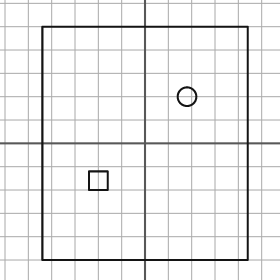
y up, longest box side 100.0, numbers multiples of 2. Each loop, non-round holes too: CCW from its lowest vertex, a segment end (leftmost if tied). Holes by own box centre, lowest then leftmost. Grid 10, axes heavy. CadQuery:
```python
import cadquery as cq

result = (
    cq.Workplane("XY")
    .moveTo(-44.0, -50.0)
    .lineTo(44.0, -50.0)
    .lineTo(44.0, 50.0)
    .lineTo(-44.0, 50.0)
    .close()
    .moveTo(-24.0, -20.0)
    .lineTo(-16.0, -20.0)
    .lineTo(-16.0, -12.0)
    .lineTo(-24.0, -12.0)
    .close()
    .moveTo(18.0, 20.0)
    .circle(4.0)
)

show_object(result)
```